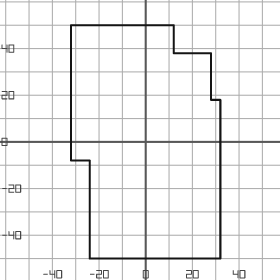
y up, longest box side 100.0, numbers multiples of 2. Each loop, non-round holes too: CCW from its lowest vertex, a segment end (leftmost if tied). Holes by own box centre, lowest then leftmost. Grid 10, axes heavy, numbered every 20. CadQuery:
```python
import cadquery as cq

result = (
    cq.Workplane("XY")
    .moveTo(-24.0, -50.0)
    .lineTo(32.0, -50.0)
    .lineTo(32.0, 18.0)
    .lineTo(28.0, 18.0)
    .lineTo(28.0, 38.0)
    .lineTo(12.0, 38.0)
    .lineTo(12.0, 50.0)
    .lineTo(-32.0, 50.0)
    .lineTo(-32.0, -8.0)
    .lineTo(-24.0, -8.0)
    .close()
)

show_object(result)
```